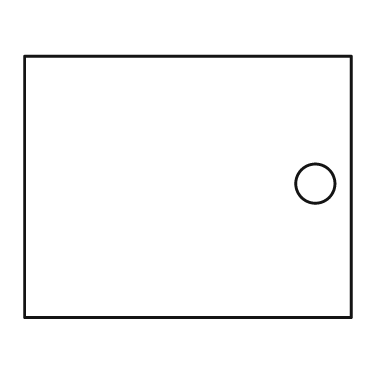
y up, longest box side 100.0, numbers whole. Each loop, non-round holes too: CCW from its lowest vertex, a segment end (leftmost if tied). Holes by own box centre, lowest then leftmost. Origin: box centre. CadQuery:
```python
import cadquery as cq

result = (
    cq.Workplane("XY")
    .moveTo(-50.0, -40.0)
    .lineTo(50.0, -40.0)
    .lineTo(50.0, 40.0)
    .lineTo(-50.0, 40.0)
    .close()
    .moveTo(39.0, 1.0)
    .circle(6.0)
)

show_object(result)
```